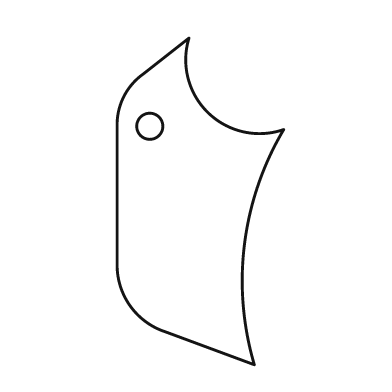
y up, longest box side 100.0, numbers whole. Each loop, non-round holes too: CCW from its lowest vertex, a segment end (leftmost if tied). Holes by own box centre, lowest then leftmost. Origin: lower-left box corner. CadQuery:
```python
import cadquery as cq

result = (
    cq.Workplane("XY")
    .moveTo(42.0, 0.0)
    .threePointArc((39.0, 37.0), (51.0, 72.0))
    .threePointArc((28.0, 77.0), (22.0, 100.0))
    .lineTo(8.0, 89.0)
    .threePointArc((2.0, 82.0), (0.0, 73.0))
    .lineTo(0.0, 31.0)
    .threePointArc((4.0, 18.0), (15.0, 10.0))
    .close()
    .moveTo(10.0, 73.0)
    .circle(4.0)
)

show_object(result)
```